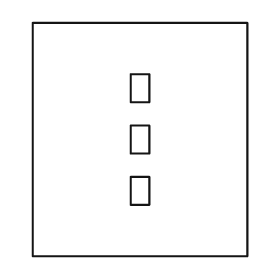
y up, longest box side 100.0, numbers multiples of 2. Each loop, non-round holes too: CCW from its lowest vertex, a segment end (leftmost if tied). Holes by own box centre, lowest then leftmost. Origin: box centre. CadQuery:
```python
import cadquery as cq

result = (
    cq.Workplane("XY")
    .moveTo(-46.0, -50.0)
    .lineTo(46.0, -50.0)
    .lineTo(46.0, 50.0)
    .lineTo(-46.0, 50.0)
    .close()
    .moveTo(-4.0, -28.0)
    .lineTo(4.0, -28.0)
    .lineTo(4.0, -16.0)
    .lineTo(-4.0, -16.0)
    .close()
    .moveTo(-4.0, -6.0)
    .lineTo(4.0, -6.0)
    .lineTo(4.0, 6.0)
    .lineTo(-4.0, 6.0)
    .close()
    .moveTo(-4.0, 16.0)
    .lineTo(4.0, 16.0)
    .lineTo(4.0, 28.0)
    .lineTo(-4.0, 28.0)
    .close()
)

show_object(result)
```